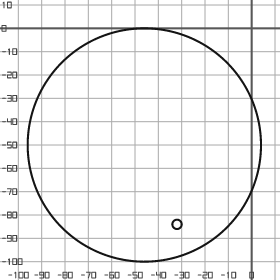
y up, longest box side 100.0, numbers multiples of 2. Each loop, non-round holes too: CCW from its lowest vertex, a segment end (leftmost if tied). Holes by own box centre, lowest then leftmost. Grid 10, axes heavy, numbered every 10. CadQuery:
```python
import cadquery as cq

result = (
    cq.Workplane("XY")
    .moveTo(-46.0, -50.0)
    .circle(50.0)
    .moveTo(-32.0, -84.0)
    .circle(2.0)
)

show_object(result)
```